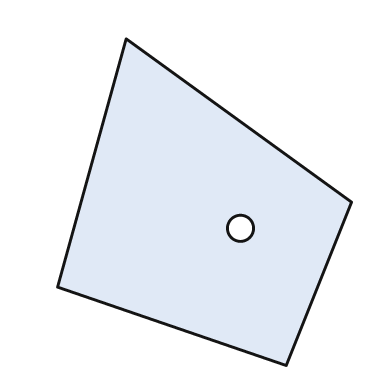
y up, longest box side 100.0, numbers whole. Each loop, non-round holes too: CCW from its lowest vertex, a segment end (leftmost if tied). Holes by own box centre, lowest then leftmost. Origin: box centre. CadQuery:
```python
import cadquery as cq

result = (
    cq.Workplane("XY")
    .moveTo(25.0, -50.0)
    .lineTo(45.0, 0.0)
    .lineTo(-24.0, 50.0)
    .lineTo(-45.0, -26.0)
    .close()
    .moveTo(11.0, -8.0)
    .circle(4.0)
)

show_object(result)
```